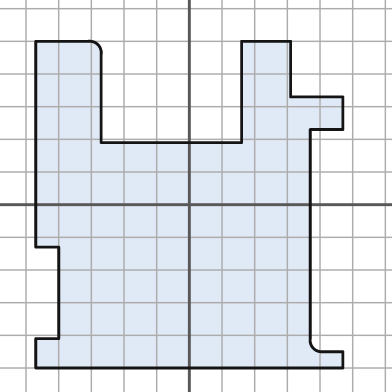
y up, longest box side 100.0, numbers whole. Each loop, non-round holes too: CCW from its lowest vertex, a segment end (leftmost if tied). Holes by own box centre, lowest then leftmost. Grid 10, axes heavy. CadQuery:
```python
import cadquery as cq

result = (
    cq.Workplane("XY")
    .moveTo(-47.0, -50.0)
    .lineTo(47.0, -50.0)
    .lineTo(47.0, -45.0)
    .lineTo(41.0, -45.0)
    .threePointArc((38.0, -44.0), (37.0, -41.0))
    .lineTo(37.0, 23.0)
    .lineTo(47.0, 23.0)
    .lineTo(47.0, 33.0)
    .lineTo(31.0, 33.0)
    .lineTo(31.0, 50.0)
    .lineTo(16.0, 50.0)
    .lineTo(16.0, 19.0)
    .lineTo(-27.0, 19.0)
    .lineTo(-27.0, 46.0)
    .threePointArc((-28.0, 49.0), (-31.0, 50.0))
    .lineTo(-47.0, 50.0)
    .lineTo(-47.0, -13.0)
    .lineTo(-40.0, -13.0)
    .lineTo(-40.0, -41.0)
    .lineTo(-47.0, -41.0)
    .close()
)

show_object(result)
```